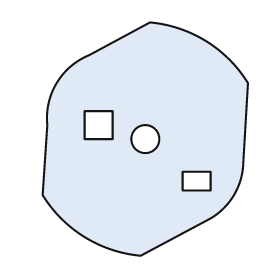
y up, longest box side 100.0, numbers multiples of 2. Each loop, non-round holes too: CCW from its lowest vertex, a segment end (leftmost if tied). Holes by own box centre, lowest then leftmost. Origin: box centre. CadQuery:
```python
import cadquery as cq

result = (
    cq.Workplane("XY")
    .moveTo(-2.0, -50.0)
    .lineTo(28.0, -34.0)
    .threePointArc((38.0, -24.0), (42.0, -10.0))
    .lineTo(44.0, 24.0)
    .threePointArc((26.0, 42.0), (2.0, 50.0))
    .lineTo(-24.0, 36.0)
    .threePointArc((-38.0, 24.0), (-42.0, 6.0))
    .lineTo(-44.0, -24.0)
    .threePointArc((-26.0, -42.0), (-2.0, -50.0))
    .close()
    .moveTo(16.0, -22.0)
    .lineTo(28.0, -22.0)
    .lineTo(28.0, -14.0)
    .lineTo(16.0, -14.0)
    .close()
    .moveTo(0.0, 0.0)
    .circle(6.0)
    .moveTo(-26.0, 0.0)
    .lineTo(-14.0, 0.0)
    .lineTo(-14.0, 12.0)
    .lineTo(-26.0, 12.0)
    .close()
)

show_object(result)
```